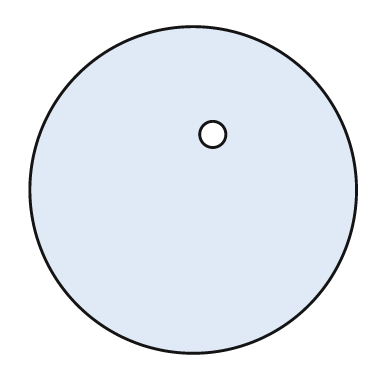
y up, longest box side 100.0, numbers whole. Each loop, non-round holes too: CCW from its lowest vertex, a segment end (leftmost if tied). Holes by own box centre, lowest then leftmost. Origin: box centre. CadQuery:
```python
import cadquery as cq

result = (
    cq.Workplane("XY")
    .moveTo(0.0, 0.0)
    .circle(50.0)
    .moveTo(6.0, 17.0)
    .circle(4.0)
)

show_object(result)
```